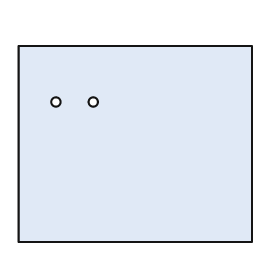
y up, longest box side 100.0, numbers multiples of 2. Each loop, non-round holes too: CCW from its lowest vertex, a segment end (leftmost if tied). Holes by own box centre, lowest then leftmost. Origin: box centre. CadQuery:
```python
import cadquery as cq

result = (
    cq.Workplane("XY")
    .moveTo(-50.0, -42.0)
    .lineTo(50.0, -42.0)
    .lineTo(50.0, 42.0)
    .lineTo(-50.0, 42.0)
    .close()
    .moveTo(-34.0, 18.0)
    .circle(2.0)
    .moveTo(-18.0, 18.0)
    .circle(2.0)
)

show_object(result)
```